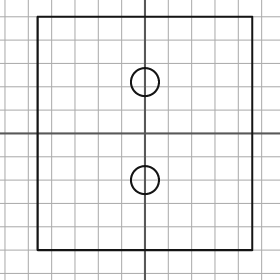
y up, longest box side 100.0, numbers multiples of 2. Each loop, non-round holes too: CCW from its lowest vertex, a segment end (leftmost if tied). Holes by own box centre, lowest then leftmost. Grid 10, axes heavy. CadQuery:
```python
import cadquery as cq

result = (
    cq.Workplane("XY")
    .moveTo(-46.0, -50.0)
    .lineTo(46.0, -50.0)
    .lineTo(46.0, 50.0)
    .lineTo(-46.0, 50.0)
    .close()
    .moveTo(0.0, -20.0)
    .circle(6.0)
    .moveTo(0.0, 22.0)
    .circle(6.0)
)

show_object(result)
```